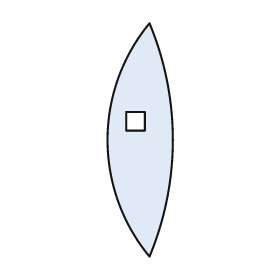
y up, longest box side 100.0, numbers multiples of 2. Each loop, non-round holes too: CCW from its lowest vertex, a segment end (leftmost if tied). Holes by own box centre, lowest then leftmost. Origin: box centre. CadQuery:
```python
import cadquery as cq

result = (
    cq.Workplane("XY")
    .moveTo(4.0, -50.0)
    .threePointArc((14.0, 0.0), (4.0, 50.0))
    .threePointArc((-14.0, 0.0), (4.0, -50.0))
    .close()
    .moveTo(-6.0, 4.0)
    .lineTo(2.0, 4.0)
    .lineTo(2.0, 12.0)
    .lineTo(-6.0, 12.0)
    .close()
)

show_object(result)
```